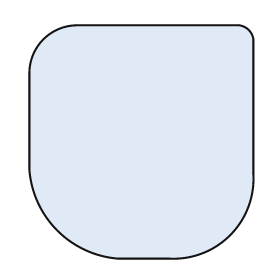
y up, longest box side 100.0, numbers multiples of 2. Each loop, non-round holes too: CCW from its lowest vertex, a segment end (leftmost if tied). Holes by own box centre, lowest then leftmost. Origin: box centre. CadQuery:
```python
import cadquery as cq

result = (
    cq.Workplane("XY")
    .moveTo(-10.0, -50.0)
    .lineTo(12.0, -50.0)
    .threePointArc((38.0, -40.0), (48.0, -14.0))
    .lineTo(48.0, 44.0)
    .threePointArc((46.0, 48.0), (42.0, 50.0))
    .lineTo(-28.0, 50.0)
    .threePointArc((-42.0, 44.0), (-48.0, 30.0))
    .lineTo(-48.0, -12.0)
    .threePointArc((-36.0, -38.0), (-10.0, -50.0))
    .close()
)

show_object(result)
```